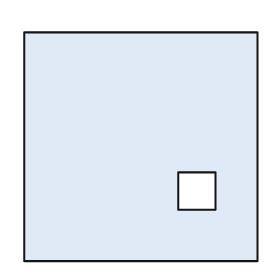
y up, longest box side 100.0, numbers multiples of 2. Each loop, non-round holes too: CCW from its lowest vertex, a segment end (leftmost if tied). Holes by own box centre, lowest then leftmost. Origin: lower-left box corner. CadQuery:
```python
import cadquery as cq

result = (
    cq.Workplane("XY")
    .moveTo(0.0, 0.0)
    .lineTo(100.0, 0.0)
    .lineTo(100.0, 98.0)
    .lineTo(0.0, 98.0)
    .close()
    .moveTo(66.0, 22.0)
    .lineTo(82.0, 22.0)
    .lineTo(82.0, 38.0)
    .lineTo(66.0, 38.0)
    .close()
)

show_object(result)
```